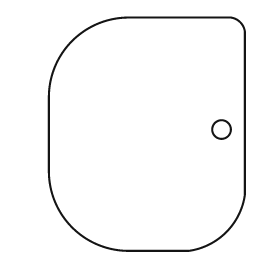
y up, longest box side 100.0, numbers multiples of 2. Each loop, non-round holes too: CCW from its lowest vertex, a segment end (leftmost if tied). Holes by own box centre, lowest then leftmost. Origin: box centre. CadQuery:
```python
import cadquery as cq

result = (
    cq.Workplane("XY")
    .moveTo(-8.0, -50.0)
    .lineTo(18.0, -50.0)
    .threePointArc((34.0, -42.0), (42.0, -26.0))
    .lineTo(42.0, 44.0)
    .threePointArc((40.0, 48.0), (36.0, 50.0))
    .lineTo(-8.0, 50.0)
    .threePointArc((-32.0, 40.0), (-42.0, 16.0))
    .lineTo(-42.0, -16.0)
    .threePointArc((-32.0, -40.0), (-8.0, -50.0))
    .close()
    .moveTo(32.0, 2.0)
    .circle(4.0)
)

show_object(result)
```